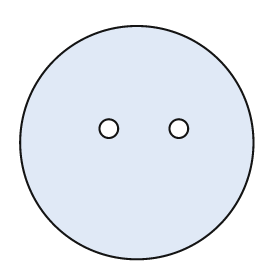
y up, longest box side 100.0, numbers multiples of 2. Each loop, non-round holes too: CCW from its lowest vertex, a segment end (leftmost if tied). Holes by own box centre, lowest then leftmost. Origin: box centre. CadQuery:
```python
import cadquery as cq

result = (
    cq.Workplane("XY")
    .moveTo(0.0, 0.0)
    .circle(50.0)
    .moveTo(-12.0, 6.0)
    .circle(4.0)
    .moveTo(18.0, 6.0)
    .circle(4.0)
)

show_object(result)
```